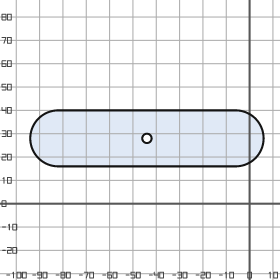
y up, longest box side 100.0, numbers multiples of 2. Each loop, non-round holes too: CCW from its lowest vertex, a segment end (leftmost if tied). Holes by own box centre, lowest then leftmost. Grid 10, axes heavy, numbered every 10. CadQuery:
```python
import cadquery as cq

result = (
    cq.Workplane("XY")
    .moveTo(-82.0, 16.0)
    .lineTo(-6.0, 16.0)
    .threePointArc((6.0, 28.0), (-6.0, 40.0))
    .lineTo(-82.0, 40.0)
    .threePointArc((-94.0, 28.0), (-82.0, 16.0))
    .close()
    .moveTo(-44.0, 28.0)
    .circle(2.0)
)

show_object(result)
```